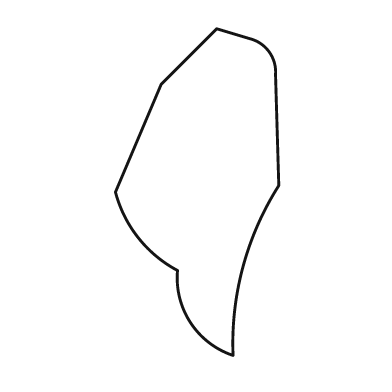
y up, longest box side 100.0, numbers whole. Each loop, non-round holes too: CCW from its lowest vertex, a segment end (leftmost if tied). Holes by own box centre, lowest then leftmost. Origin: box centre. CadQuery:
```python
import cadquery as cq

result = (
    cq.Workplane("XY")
    .moveTo(11.0, -50.0)
    .threePointArc((14.0, -23.0), (25.0, 2.0))
    .lineTo(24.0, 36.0)
    .threePointArc((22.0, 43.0), (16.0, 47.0))
    .lineTo(6.0, 50.0)
    .lineTo(-11.0, 33.0)
    .lineTo(-25.0, 0.0)
    .threePointArc((-18.0, -14.0), (-6.0, -24.0))
    .threePointArc((-2.0, -40.0), (11.0, -50.0))
    .close()
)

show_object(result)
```